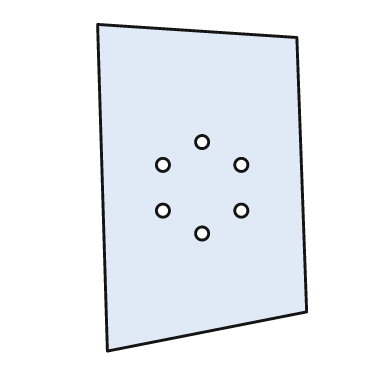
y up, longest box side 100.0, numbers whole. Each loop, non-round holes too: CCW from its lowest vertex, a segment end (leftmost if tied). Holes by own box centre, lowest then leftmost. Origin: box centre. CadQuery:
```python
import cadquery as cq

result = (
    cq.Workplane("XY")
    .moveTo(-29.0, -50.0)
    .lineTo(32.0, -38.0)
    .lineTo(29.0, 46.0)
    .lineTo(-32.0, 50.0)
    .close()
    .moveTo(0.0, -14.0)
    .circle(2.0)
    .moveTo(-12.0, -7.0)
    .circle(2.0)
    .moveTo(12.0, -7.0)
    .circle(2.0)
    .moveTo(-12.0, 7.0)
    .circle(2.0)
    .moveTo(12.0, 7.0)
    .circle(2.0)
    .moveTo(0.0, 14.0)
    .circle(2.0)
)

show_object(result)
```